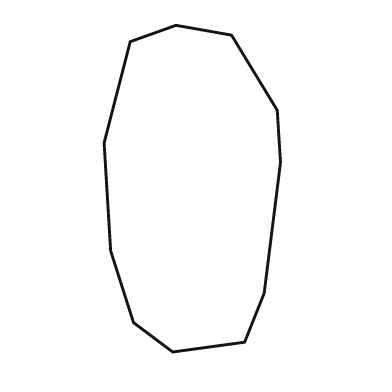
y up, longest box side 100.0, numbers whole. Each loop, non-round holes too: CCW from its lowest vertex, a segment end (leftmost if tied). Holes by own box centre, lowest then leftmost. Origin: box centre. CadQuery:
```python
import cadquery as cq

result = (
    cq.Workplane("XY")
    .moveTo(-6.0, -50.0)
    .lineTo(16.0, -47.0)
    .lineTo(22.0, -32.0)
    .lineTo(27.0, 8.0)
    .lineTo(26.0, 24.0)
    .lineTo(12.0, 47.0)
    .lineTo(-5.0, 50.0)
    .lineTo(-19.0, 45.0)
    .lineTo(-27.0, 14.0)
    .lineTo(-25.0, -19.0)
    .lineTo(-18.0, -41.0)
    .close()
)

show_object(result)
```